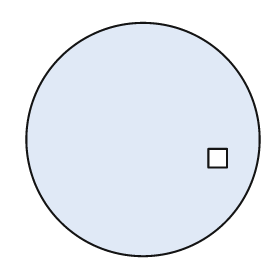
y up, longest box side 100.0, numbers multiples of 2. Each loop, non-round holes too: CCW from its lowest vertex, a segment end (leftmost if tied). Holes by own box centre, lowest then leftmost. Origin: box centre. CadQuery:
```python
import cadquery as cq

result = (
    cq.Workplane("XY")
    .moveTo(0.0, 0.0)
    .circle(50.0)
    .moveTo(28.0, -12.0)
    .lineTo(36.0, -12.0)
    .lineTo(36.0, -4.0)
    .lineTo(28.0, -4.0)
    .close()
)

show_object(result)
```